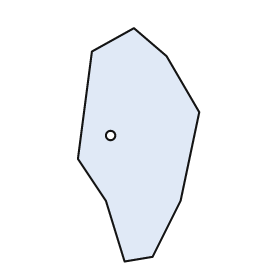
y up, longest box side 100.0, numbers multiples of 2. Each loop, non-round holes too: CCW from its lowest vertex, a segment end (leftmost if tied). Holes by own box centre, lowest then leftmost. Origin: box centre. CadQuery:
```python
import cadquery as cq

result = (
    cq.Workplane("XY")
    .moveTo(-6.0, -50.0)
    .lineTo(6.0, -48.0)
    .lineTo(18.0, -24.0)
    .lineTo(26.0, 14.0)
    .lineTo(12.0, 38.0)
    .lineTo(-2.0, 50.0)
    .lineTo(-20.0, 40.0)
    .lineTo(-26.0, -6.0)
    .lineTo(-14.0, -24.0)
    .close()
    .moveTo(-12.0, 4.0)
    .circle(2.0)
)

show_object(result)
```